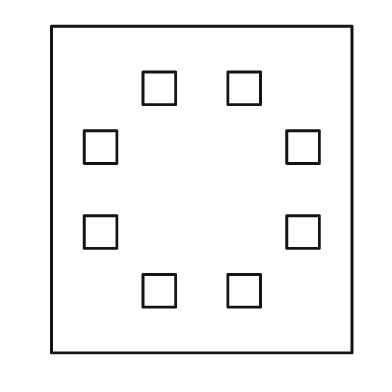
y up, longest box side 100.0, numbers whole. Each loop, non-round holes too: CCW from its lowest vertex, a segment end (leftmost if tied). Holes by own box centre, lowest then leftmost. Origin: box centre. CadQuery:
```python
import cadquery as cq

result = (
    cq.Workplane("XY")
    .moveTo(-46.0, -50.0)
    .lineTo(46.0, -50.0)
    .lineTo(46.0, 50.0)
    .lineTo(-46.0, 50.0)
    .close()
    .moveTo(-18.0, -36.0)
    .lineTo(-8.0, -36.0)
    .lineTo(-8.0, -26.0)
    .lineTo(-18.0, -26.0)
    .close()
    .moveTo(8.0, -36.0)
    .lineTo(18.0, -36.0)
    .lineTo(18.0, -26.0)
    .lineTo(8.0, -26.0)
    .close()
    .moveTo(-36.0, -18.0)
    .lineTo(-26.0, -18.0)
    .lineTo(-26.0, -8.0)
    .lineTo(-36.0, -8.0)
    .close()
    .moveTo(26.0, -18.0)
    .lineTo(36.0, -18.0)
    .lineTo(36.0, -8.0)
    .lineTo(26.0, -8.0)
    .close()
    .moveTo(-36.0, 8.0)
    .lineTo(-26.0, 8.0)
    .lineTo(-26.0, 18.0)
    .lineTo(-36.0, 18.0)
    .close()
    .moveTo(26.0, 8.0)
    .lineTo(36.0, 8.0)
    .lineTo(36.0, 18.0)
    .lineTo(26.0, 18.0)
    .close()
    .moveTo(-18.0, 26.0)
    .lineTo(-8.0, 26.0)
    .lineTo(-8.0, 36.0)
    .lineTo(-18.0, 36.0)
    .close()
    .moveTo(8.0, 26.0)
    .lineTo(18.0, 26.0)
    .lineTo(18.0, 36.0)
    .lineTo(8.0, 36.0)
    .close()
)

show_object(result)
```